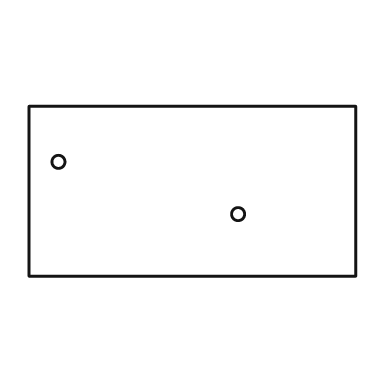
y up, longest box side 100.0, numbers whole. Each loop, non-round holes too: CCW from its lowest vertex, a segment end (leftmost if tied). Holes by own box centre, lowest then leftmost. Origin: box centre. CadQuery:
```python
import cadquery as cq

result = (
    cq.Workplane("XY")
    .moveTo(-50.0, -26.0)
    .lineTo(50.0, -26.0)
    .lineTo(50.0, 26.0)
    .lineTo(-50.0, 26.0)
    .close()
    .moveTo(14.0, -7.0)
    .circle(2.0)
    .moveTo(-41.0, 9.0)
    .circle(2.0)
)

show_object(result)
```